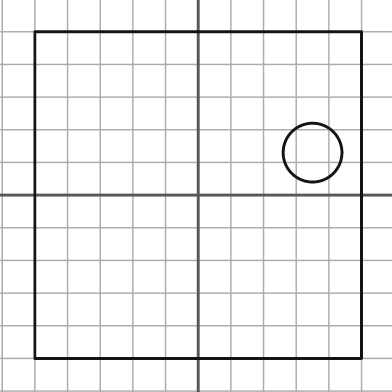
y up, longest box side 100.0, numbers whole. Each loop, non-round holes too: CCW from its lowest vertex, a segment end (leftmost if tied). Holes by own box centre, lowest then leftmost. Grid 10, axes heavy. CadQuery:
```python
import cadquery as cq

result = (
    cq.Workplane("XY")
    .moveTo(-50.0, -50.0)
    .lineTo(50.0, -50.0)
    .lineTo(50.0, 50.0)
    .lineTo(-50.0, 50.0)
    .close()
    .moveTo(35.0, 13.0)
    .circle(9.0)
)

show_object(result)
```